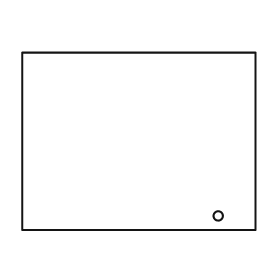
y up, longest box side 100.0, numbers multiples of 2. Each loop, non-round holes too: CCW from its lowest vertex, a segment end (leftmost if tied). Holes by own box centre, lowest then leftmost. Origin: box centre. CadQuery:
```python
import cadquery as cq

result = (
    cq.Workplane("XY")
    .moveTo(-50.0, -38.0)
    .lineTo(50.0, -38.0)
    .lineTo(50.0, 38.0)
    .lineTo(-50.0, 38.0)
    .close()
    .moveTo(34.0, -32.0)
    .circle(2.0)
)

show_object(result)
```